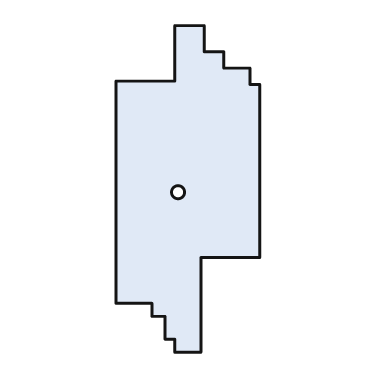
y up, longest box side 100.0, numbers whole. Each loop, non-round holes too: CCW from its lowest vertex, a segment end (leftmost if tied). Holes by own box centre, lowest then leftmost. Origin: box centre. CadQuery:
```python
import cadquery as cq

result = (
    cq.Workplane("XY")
    .moveTo(-4.0, -50.0)
    .lineTo(4.0, -50.0)
    .lineTo(4.0, -21.0)
    .lineTo(22.0, -21.0)
    .lineTo(22.0, 32.0)
    .lineTo(19.0, 32.0)
    .lineTo(19.0, 37.0)
    .lineTo(11.0, 37.0)
    .lineTo(11.0, 42.0)
    .lineTo(5.0, 42.0)
    .lineTo(5.0, 50.0)
    .lineTo(-4.0, 50.0)
    .lineTo(-4.0, 33.0)
    .lineTo(-22.0, 33.0)
    .lineTo(-22.0, -35.0)
    .lineTo(-11.0, -35.0)
    .lineTo(-11.0, -39.0)
    .lineTo(-7.0, -39.0)
    .lineTo(-7.0, -46.0)
    .lineTo(-4.0, -46.0)
    .close()
    .moveTo(-3.0, -1.0)
    .circle(2.0)
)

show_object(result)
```